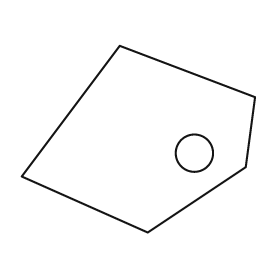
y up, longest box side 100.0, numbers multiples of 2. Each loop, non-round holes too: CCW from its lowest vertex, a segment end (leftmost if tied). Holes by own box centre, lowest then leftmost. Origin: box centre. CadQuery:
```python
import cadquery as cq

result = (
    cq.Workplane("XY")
    .moveTo(4.0, -40.0)
    .lineTo(46.0, -12.0)
    .lineTo(50.0, 18.0)
    .lineTo(-8.0, 40.0)
    .lineTo(-50.0, -16.0)
    .close()
    .moveTo(24.0, -6.0)
    .circle(8.0)
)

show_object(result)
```